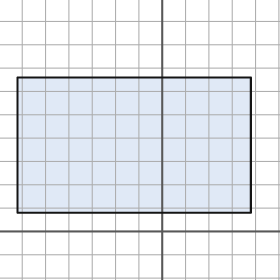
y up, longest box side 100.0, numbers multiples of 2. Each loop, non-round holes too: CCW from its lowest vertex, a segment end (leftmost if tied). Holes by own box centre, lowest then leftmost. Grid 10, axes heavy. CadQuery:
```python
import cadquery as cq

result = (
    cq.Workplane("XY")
    .moveTo(-62.0, 8.0)
    .lineTo(38.0, 8.0)
    .lineTo(38.0, 66.0)
    .lineTo(-62.0, 66.0)
    .close()
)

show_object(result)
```